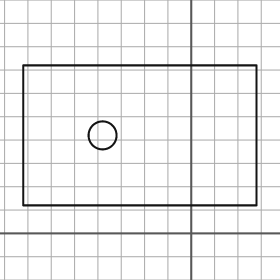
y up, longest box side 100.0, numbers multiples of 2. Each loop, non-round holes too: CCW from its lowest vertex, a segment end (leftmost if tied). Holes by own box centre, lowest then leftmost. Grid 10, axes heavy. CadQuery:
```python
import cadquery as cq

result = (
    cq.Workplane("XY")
    .moveTo(-72.0, 12.0)
    .lineTo(28.0, 12.0)
    .lineTo(28.0, 72.0)
    .lineTo(-72.0, 72.0)
    .close()
    .moveTo(-38.0, 42.0)
    .circle(6.0)
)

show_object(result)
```